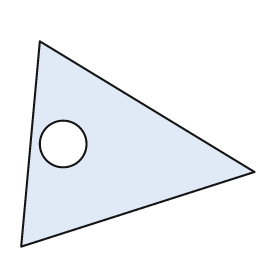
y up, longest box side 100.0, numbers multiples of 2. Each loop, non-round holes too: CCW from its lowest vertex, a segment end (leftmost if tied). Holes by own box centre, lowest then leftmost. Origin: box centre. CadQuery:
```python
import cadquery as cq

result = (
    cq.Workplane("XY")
    .moveTo(-50.0, -44.0)
    .lineTo(50.0, -12.0)
    .lineTo(-42.0, 44.0)
    .close()
    .moveTo(-32.0, 0.0)
    .circle(10.0)
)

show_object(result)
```